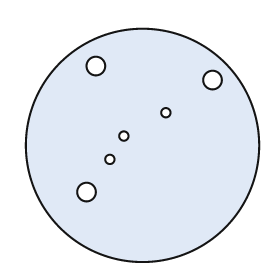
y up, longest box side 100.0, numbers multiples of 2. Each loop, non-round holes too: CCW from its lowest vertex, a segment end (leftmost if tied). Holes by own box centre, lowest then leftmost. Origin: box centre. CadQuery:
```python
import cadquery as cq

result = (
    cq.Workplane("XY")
    .moveTo(0.0, 0.0)
    .circle(50.0)
    .moveTo(-24.0, -20.0)
    .circle(4.0)
    .moveTo(-14.0, -6.0)
    .circle(2.0)
    .moveTo(-8.0, 4.0)
    .circle(2.0)
    .moveTo(10.0, 14.0)
    .circle(2.0)
    .moveTo(30.0, 28.0)
    .circle(4.0)
    .moveTo(-20.0, 34.0)
    .circle(4.0)
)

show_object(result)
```